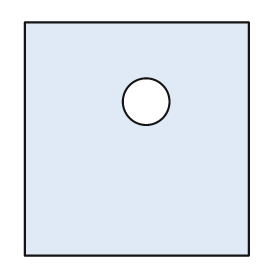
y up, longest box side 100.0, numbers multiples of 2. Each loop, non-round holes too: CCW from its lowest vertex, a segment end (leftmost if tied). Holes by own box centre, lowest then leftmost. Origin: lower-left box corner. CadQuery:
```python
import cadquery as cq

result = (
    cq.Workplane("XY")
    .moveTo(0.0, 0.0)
    .lineTo(96.0, 0.0)
    .lineTo(96.0, 100.0)
    .lineTo(0.0, 100.0)
    .close()
    .moveTo(52.0, 66.0)
    .circle(10.0)
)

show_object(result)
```